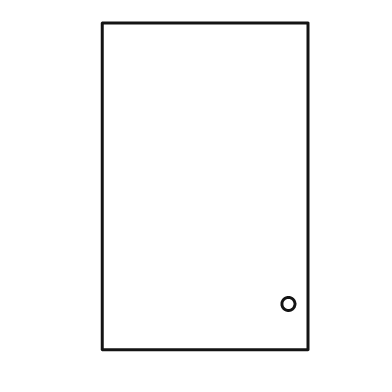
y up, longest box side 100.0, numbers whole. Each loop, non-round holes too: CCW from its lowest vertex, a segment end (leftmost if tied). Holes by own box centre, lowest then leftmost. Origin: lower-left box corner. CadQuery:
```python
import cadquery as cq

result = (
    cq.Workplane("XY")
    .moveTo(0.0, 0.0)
    .lineTo(63.0, 0.0)
    .lineTo(63.0, 100.0)
    .lineTo(0.0, 100.0)
    .close()
    .moveTo(57.0, 14.0)
    .circle(2.0)
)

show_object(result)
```